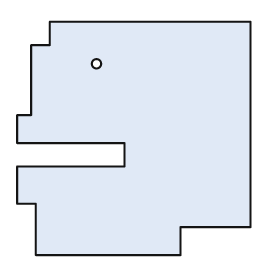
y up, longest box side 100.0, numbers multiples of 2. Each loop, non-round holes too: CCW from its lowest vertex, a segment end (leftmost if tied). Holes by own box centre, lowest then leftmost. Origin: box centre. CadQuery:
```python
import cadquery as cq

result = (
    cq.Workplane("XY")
    .moveTo(-42.0, -50.0)
    .lineTo(20.0, -50.0)
    .lineTo(20.0, -38.0)
    .lineTo(50.0, -38.0)
    .lineTo(50.0, 50.0)
    .lineTo(-36.0, 50.0)
    .lineTo(-36.0, 40.0)
    .lineTo(-44.0, 40.0)
    .lineTo(-44.0, 10.0)
    .lineTo(-50.0, 10.0)
    .lineTo(-50.0, -2.0)
    .lineTo(-4.0, -2.0)
    .lineTo(-4.0, -12.0)
    .lineTo(-50.0, -12.0)
    .lineTo(-50.0, -28.0)
    .lineTo(-42.0, -28.0)
    .close()
    .moveTo(-16.0, 32.0)
    .circle(2.0)
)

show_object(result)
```